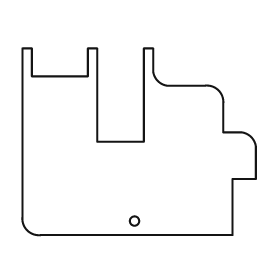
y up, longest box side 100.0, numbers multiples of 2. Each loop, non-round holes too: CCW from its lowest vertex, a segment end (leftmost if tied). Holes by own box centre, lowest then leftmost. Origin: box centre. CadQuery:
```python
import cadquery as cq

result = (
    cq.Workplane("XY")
    .moveTo(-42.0, -40.0)
    .lineTo(40.0, -40.0)
    .lineTo(40.0, -16.0)
    .lineTo(50.0, -16.0)
    .lineTo(50.0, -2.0)
    .threePointArc((48.0, 2.0), (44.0, 4.0))
    .lineTo(36.0, 4.0)
    .lineTo(36.0, 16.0)
    .threePointArc((34.0, 22.0), (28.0, 24.0))
    .lineTo(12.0, 24.0)
    .threePointArc((8.0, 26.0), (6.0, 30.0))
    .lineTo(6.0, 40.0)
    .lineTo(2.0, 40.0)
    .lineTo(2.0, 0.0)
    .lineTo(-18.0, 0.0)
    .lineTo(-18.0, 40.0)
    .lineTo(-22.0, 40.0)
    .lineTo(-22.0, 28.0)
    .lineTo(-46.0, 28.0)
    .lineTo(-46.0, 40.0)
    .lineTo(-50.0, 40.0)
    .lineTo(-50.0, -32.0)
    .threePointArc((-48.0, -38.0), (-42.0, -40.0))
    .close()
    .moveTo(-2.0, -34.0)
    .circle(2.0)
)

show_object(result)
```